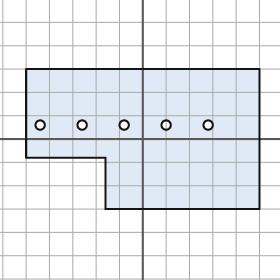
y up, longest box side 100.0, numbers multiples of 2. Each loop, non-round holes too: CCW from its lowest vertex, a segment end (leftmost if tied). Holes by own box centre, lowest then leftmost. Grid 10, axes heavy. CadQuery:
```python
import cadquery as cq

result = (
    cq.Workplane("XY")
    .moveTo(-16.0, -30.0)
    .lineTo(50.0, -30.0)
    .lineTo(50.0, 30.0)
    .lineTo(-50.0, 30.0)
    .lineTo(-50.0, -8.0)
    .lineTo(-16.0, -8.0)
    .close()
    .moveTo(-44.0, 6.0)
    .circle(2.0)
    .moveTo(-26.0, 6.0)
    .circle(2.0)
    .moveTo(-8.0, 6.0)
    .circle(2.0)
    .moveTo(10.0, 6.0)
    .circle(2.0)
    .moveTo(28.0, 6.0)
    .circle(2.0)
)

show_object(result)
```